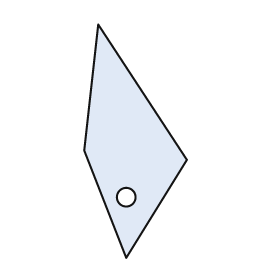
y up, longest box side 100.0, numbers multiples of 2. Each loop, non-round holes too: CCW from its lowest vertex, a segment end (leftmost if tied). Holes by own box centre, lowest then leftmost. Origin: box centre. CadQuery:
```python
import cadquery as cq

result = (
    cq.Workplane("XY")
    .moveTo(-4.0, -50.0)
    .lineTo(22.0, -8.0)
    .lineTo(-16.0, 50.0)
    .lineTo(-22.0, -4.0)
    .close()
    .moveTo(-4.0, -24.0)
    .circle(4.0)
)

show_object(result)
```